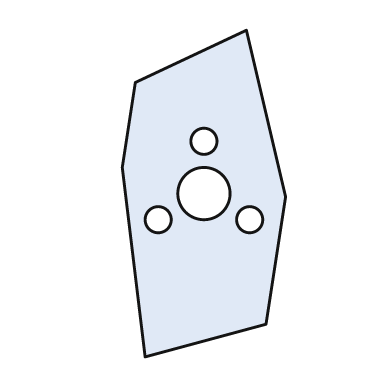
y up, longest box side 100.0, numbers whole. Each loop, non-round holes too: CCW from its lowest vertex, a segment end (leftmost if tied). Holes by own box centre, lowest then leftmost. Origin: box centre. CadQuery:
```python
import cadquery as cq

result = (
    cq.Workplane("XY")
    .moveTo(-18.0, -50.0)
    .lineTo(19.0, -40.0)
    .lineTo(25.0, -1.0)
    .lineTo(13.0, 50.0)
    .lineTo(-21.0, 34.0)
    .lineTo(-25.0, 8.0)
    .close()
    .moveTo(-14.0, -8.0)
    .circle(4.0)
    .moveTo(14.0, -8.0)
    .circle(4.0)
    .moveTo(0.0, 0.0)
    .circle(8.0)
    .moveTo(0.0, 16.0)
    .circle(4.0)
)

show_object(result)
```